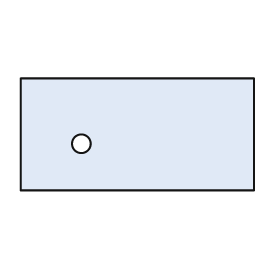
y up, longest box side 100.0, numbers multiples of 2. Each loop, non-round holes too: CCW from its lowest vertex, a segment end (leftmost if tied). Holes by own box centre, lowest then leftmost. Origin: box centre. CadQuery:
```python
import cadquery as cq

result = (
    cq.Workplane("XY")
    .moveTo(-50.0, -24.0)
    .lineTo(50.0, -24.0)
    .lineTo(50.0, 24.0)
    .lineTo(-50.0, 24.0)
    .close()
    .moveTo(-24.0, -4.0)
    .circle(4.0)
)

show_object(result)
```